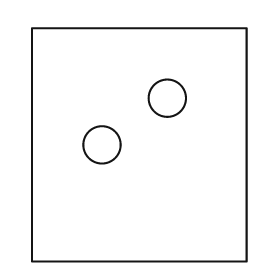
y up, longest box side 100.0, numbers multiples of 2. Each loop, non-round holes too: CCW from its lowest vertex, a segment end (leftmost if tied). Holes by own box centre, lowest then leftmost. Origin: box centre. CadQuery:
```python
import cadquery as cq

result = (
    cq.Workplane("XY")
    .moveTo(-46.0, -50.0)
    .lineTo(46.0, -50.0)
    .lineTo(46.0, 50.0)
    .lineTo(-46.0, 50.0)
    .close()
    .moveTo(-16.0, 0.0)
    .circle(8.0)
    .moveTo(12.0, 20.0)
    .circle(8.0)
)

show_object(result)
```